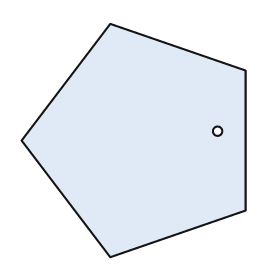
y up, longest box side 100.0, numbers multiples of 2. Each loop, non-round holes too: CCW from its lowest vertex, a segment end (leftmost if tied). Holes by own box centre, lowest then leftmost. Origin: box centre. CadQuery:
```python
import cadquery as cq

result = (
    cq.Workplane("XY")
    .moveTo(-10.0, -50.0)
    .lineTo(48.0, -30.0)
    .lineTo(48.0, 30.0)
    .lineTo(-10.0, 50.0)
    .lineTo(-48.0, 0.0)
    .close()
    .moveTo(36.0, 4.0)
    .circle(2.0)
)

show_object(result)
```